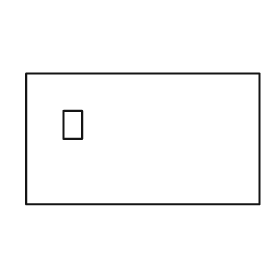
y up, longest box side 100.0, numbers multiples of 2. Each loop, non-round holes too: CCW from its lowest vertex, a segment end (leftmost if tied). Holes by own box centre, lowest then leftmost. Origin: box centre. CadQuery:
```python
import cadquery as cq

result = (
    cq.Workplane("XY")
    .moveTo(-50.0, -28.0)
    .lineTo(50.0, -28.0)
    .lineTo(50.0, 28.0)
    .lineTo(-50.0, 28.0)
    .close()
    .moveTo(-34.0, 0.0)
    .lineTo(-26.0, 0.0)
    .lineTo(-26.0, 12.0)
    .lineTo(-34.0, 12.0)
    .close()
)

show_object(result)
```